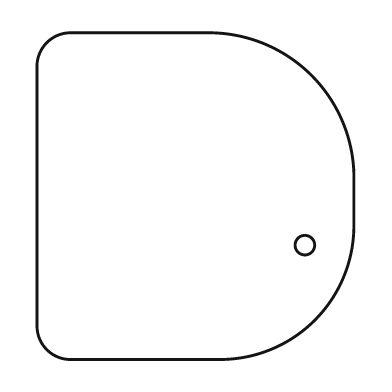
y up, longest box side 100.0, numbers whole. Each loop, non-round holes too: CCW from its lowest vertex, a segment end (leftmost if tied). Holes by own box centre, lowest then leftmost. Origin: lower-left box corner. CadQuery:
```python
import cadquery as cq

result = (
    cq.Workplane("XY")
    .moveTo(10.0, 0.0)
    .lineTo(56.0, 0.0)
    .threePointArc((85.0, 12.0), (97.0, 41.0))
    .lineTo(97.0, 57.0)
    .threePointArc((84.0, 87.0), (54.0, 100.0))
    .lineTo(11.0, 100.0)
    .threePointArc((3.0, 97.0), (0.0, 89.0))
    .lineTo(0.0, 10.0)
    .threePointArc((3.0, 3.0), (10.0, 0.0))
    .close()
    .moveTo(82.0, 35.0)
    .circle(3.0)
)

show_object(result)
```